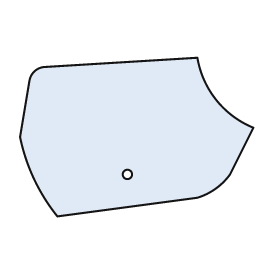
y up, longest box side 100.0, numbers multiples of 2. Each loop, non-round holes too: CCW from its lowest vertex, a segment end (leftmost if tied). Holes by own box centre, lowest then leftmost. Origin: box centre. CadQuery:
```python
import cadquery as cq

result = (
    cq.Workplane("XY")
    .moveTo(-34.0, -34.0)
    .lineTo(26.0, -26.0)
    .threePointArc((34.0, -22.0), (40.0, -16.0))
    .lineTo(50.0, 4.0)
    .threePointArc((34.0, 16.0), (26.0, 34.0))
    .lineTo(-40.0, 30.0)
    .threePointArc((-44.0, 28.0), (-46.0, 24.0))
    .lineTo(-50.0, 0.0)
    .threePointArc((-44.0, -18.0), (-34.0, -34.0))
    .close()
    .moveTo(-4.0, -16.0)
    .circle(2.0)
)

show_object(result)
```